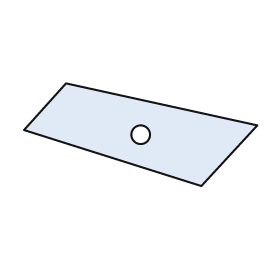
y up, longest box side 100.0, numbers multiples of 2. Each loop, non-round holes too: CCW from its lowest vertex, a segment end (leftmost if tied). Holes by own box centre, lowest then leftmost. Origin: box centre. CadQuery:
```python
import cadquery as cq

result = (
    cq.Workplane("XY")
    .moveTo(26.0, -22.0)
    .lineTo(50.0, 4.0)
    .lineTo(-32.0, 22.0)
    .lineTo(-50.0, 2.0)
    .close()
    .moveTo(0.0, 0.0)
    .circle(4.0)
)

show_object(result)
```